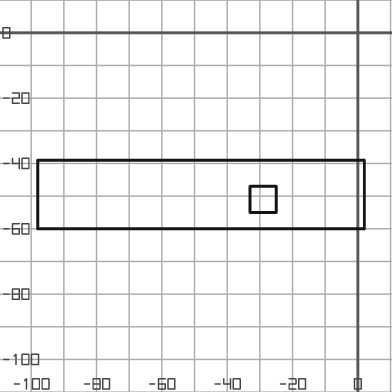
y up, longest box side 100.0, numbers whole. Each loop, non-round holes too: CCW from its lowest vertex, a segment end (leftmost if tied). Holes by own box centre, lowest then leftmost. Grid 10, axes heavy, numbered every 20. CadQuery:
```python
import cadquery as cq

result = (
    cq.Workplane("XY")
    .moveTo(-98.0, -60.0)
    .lineTo(2.0, -60.0)
    .lineTo(2.0, -39.0)
    .lineTo(-98.0, -39.0)
    .close()
    .moveTo(-33.0, -55.0)
    .lineTo(-25.0, -55.0)
    .lineTo(-25.0, -47.0)
    .lineTo(-33.0, -47.0)
    .close()
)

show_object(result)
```